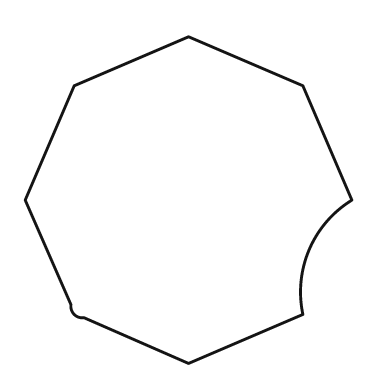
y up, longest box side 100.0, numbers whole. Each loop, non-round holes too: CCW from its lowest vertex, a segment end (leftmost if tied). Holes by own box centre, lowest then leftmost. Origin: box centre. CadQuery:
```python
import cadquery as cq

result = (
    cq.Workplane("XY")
    .moveTo(0.0, -50.0)
    .lineTo(35.0, -35.0)
    .threePointArc((37.0, -15.0), (50.0, 0.0))
    .lineTo(35.0, 35.0)
    .lineTo(0.0, 50.0)
    .lineTo(-35.0, 35.0)
    .lineTo(-50.0, 0.0)
    .lineTo(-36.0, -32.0)
    .threePointArc((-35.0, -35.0), (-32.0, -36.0))
    .close()
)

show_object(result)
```